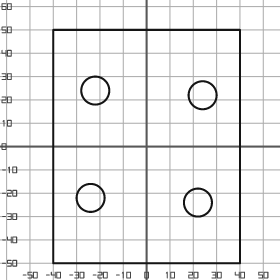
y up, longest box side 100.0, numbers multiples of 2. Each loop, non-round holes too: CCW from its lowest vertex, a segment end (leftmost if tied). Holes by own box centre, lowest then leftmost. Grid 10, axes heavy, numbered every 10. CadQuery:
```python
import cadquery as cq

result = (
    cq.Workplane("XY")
    .moveTo(-40.0, -50.0)
    .lineTo(40.0, -50.0)
    .lineTo(40.0, 50.0)
    .lineTo(-40.0, 50.0)
    .close()
    .moveTo(22.0, -24.0)
    .circle(6.0)
    .moveTo(-24.0, -22.0)
    .circle(6.0)
    .moveTo(24.0, 22.0)
    .circle(6.0)
    .moveTo(-22.0, 24.0)
    .circle(6.0)
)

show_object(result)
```